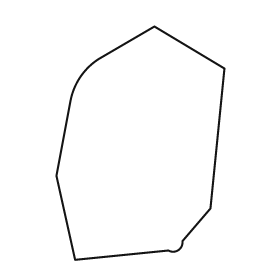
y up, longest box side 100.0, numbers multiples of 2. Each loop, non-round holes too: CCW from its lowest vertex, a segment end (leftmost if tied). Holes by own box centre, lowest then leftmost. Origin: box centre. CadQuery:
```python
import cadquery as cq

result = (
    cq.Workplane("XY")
    .moveTo(-28.0, -50.0)
    .lineTo(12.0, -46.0)
    .threePointArc((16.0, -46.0), (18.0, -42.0))
    .lineTo(30.0, -28.0)
    .lineTo(36.0, 32.0)
    .lineTo(6.0, 50.0)
    .lineTo(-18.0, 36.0)
    .threePointArc((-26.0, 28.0), (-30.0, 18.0))
    .lineTo(-36.0, -14.0)
    .close()
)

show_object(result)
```